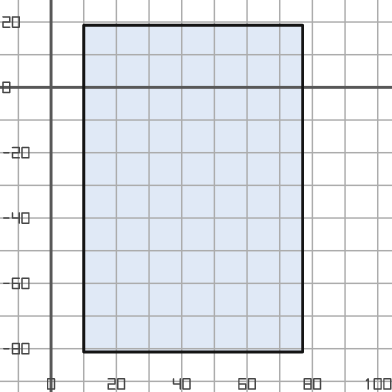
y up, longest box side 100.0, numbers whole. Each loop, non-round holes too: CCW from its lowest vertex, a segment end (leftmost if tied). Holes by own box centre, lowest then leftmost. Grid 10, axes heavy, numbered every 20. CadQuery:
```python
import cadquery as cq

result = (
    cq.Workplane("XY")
    .moveTo(10.0, -81.0)
    .lineTo(77.0, -81.0)
    .lineTo(77.0, 19.0)
    .lineTo(10.0, 19.0)
    .close()
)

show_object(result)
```